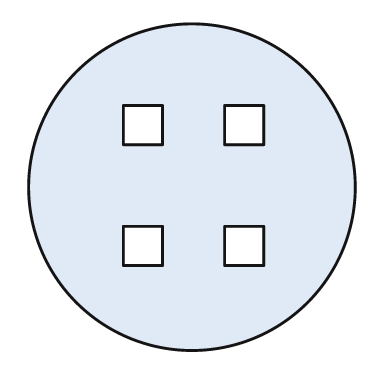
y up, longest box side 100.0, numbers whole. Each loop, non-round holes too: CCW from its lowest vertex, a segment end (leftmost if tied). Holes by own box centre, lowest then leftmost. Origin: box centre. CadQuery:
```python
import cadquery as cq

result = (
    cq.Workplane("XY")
    .moveTo(0.0, 0.0)
    .circle(50.0)
    .moveTo(-21.0, -24.0)
    .lineTo(-9.0, -24.0)
    .lineTo(-9.0, -12.0)
    .lineTo(-21.0, -12.0)
    .close()
    .moveTo(10.0, -24.0)
    .lineTo(22.0, -24.0)
    .lineTo(22.0, -12.0)
    .lineTo(10.0, -12.0)
    .close()
    .moveTo(-21.0, 13.0)
    .lineTo(-9.0, 13.0)
    .lineTo(-9.0, 25.0)
    .lineTo(-21.0, 25.0)
    .close()
    .moveTo(10.0, 13.0)
    .lineTo(22.0, 13.0)
    .lineTo(22.0, 25.0)
    .lineTo(10.0, 25.0)
    .close()
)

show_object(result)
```